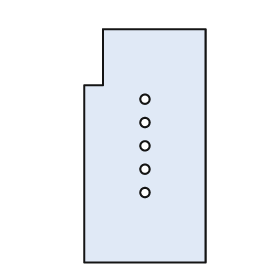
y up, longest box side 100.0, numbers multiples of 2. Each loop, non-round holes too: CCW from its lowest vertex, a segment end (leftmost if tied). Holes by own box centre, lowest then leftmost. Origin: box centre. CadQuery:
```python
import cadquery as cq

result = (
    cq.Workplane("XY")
    .moveTo(-26.0, -50.0)
    .lineTo(26.0, -50.0)
    .lineTo(26.0, 50.0)
    .lineTo(-18.0, 50.0)
    .lineTo(-18.0, 26.0)
    .lineTo(-26.0, 26.0)
    .close()
    .moveTo(0.0, -20.0)
    .circle(2.0)
    .moveTo(0.0, -10.0)
    .circle(2.0)
    .moveTo(0.0, 0.0)
    .circle(2.0)
    .moveTo(0.0, 10.0)
    .circle(2.0)
    .moveTo(0.0, 20.0)
    .circle(2.0)
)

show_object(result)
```